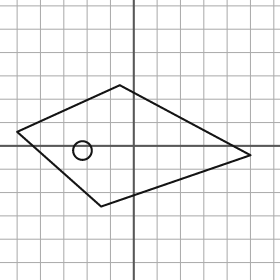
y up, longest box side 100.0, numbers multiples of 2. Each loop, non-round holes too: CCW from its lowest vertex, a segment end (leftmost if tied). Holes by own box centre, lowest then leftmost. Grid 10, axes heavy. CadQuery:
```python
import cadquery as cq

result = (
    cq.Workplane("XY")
    .moveTo(-14.0, -26.0)
    .lineTo(50.0, -4.0)
    .lineTo(-6.0, 26.0)
    .lineTo(-50.0, 6.0)
    .close()
    .moveTo(-22.0, -2.0)
    .circle(4.0)
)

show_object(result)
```